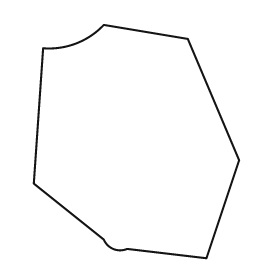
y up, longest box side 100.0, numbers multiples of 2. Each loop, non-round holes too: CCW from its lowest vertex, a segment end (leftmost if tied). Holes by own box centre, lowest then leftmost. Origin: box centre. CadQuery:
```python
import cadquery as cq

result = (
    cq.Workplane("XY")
    .moveTo(30.0, -50.0)
    .lineTo(44.0, -8.0)
    .lineTo(22.0, 44.0)
    .lineTo(-14.0, 50.0)
    .threePointArc((-26.0, 42.0), (-40.0, 40.0))
    .lineTo(-44.0, -18.0)
    .lineTo(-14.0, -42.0)
    .threePointArc((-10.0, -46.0), (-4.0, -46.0))
    .close()
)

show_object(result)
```